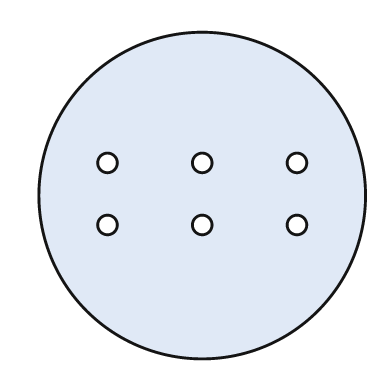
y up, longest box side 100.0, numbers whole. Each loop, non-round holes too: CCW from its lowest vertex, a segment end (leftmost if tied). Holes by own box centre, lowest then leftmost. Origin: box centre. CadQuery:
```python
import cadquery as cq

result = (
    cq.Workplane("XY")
    .moveTo(0.0, 0.0)
    .circle(50.0)
    .moveTo(-29.0, -9.0)
    .circle(3.0)
    .moveTo(0.0, -9.0)
    .circle(3.0)
    .moveTo(29.0, -9.0)
    .circle(3.0)
    .moveTo(-29.0, 10.0)
    .circle(3.0)
    .moveTo(0.0, 10.0)
    .circle(3.0)
    .moveTo(29.0, 10.0)
    .circle(3.0)
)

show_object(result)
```